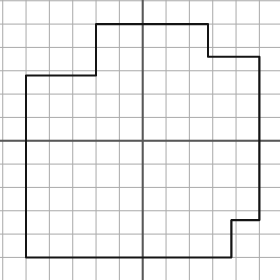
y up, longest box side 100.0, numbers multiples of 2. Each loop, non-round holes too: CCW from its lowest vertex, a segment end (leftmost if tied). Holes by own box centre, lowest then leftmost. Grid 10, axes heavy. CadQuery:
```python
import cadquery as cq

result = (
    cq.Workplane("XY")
    .moveTo(-50.0, -50.0)
    .lineTo(38.0, -50.0)
    .lineTo(38.0, -34.0)
    .lineTo(50.0, -34.0)
    .lineTo(50.0, 36.0)
    .lineTo(28.0, 36.0)
    .lineTo(28.0, 50.0)
    .lineTo(-20.0, 50.0)
    .lineTo(-20.0, 28.0)
    .lineTo(-50.0, 28.0)
    .close()
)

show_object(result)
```